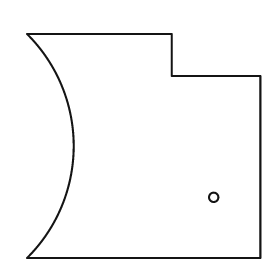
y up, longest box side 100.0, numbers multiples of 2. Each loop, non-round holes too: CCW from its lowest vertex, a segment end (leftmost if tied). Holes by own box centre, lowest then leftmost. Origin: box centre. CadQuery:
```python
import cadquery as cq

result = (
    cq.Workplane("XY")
    .moveTo(-50.0, -48.0)
    .lineTo(50.0, -48.0)
    .lineTo(50.0, 30.0)
    .lineTo(12.0, 30.0)
    .lineTo(12.0, 48.0)
    .lineTo(-50.0, 48.0)
    .threePointArc((-30.0, 0.0), (-50.0, -48.0))
    .close()
    .moveTo(30.0, -22.0)
    .circle(2.0)
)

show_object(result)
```